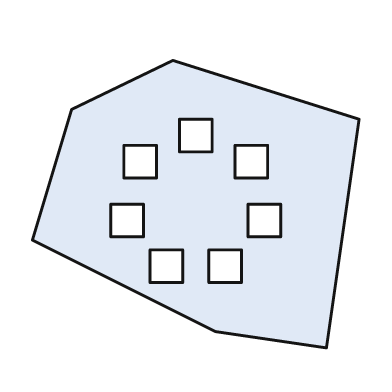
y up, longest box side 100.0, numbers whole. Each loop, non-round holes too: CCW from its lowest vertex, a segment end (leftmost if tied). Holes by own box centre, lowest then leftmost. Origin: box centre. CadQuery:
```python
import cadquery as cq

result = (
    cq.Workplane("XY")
    .moveTo(40.0, -44.0)
    .lineTo(50.0, 26.0)
    .lineTo(-7.0, 44.0)
    .lineTo(-38.0, 29.0)
    .lineTo(-50.0, -11.0)
    .lineTo(6.0, -39.0)
    .close()
    .moveTo(-14.0, -24.0)
    .lineTo(-4.0, -24.0)
    .lineTo(-4.0, -14.0)
    .lineTo(-14.0, -14.0)
    .close()
    .moveTo(4.0, -24.0)
    .lineTo(14.0, -24.0)
    .lineTo(14.0, -14.0)
    .lineTo(4.0, -14.0)
    .close()
    .moveTo(-26.0, -10.0)
    .lineTo(-16.0, -10.0)
    .lineTo(-16.0, 0.0)
    .lineTo(-26.0, 0.0)
    .close()
    .moveTo(16.0, -10.0)
    .lineTo(26.0, -10.0)
    .lineTo(26.0, 0.0)
    .lineTo(16.0, 0.0)
    .close()
    .moveTo(-22.0, 8.0)
    .lineTo(-12.0, 8.0)
    .lineTo(-12.0, 18.0)
    .lineTo(-22.0, 18.0)
    .close()
    .moveTo(12.0, 8.0)
    .lineTo(22.0, 8.0)
    .lineTo(22.0, 18.0)
    .lineTo(12.0, 18.0)
    .close()
    .moveTo(-5.0, 16.0)
    .lineTo(5.0, 16.0)
    .lineTo(5.0, 26.0)
    .lineTo(-5.0, 26.0)
    .close()
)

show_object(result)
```